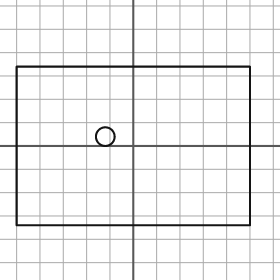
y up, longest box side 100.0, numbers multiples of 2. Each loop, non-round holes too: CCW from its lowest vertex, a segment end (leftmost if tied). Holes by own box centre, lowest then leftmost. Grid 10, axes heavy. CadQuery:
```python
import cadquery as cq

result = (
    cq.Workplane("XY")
    .moveTo(-50.0, -34.0)
    .lineTo(50.0, -34.0)
    .lineTo(50.0, 34.0)
    .lineTo(-50.0, 34.0)
    .close()
    .moveTo(-12.0, 4.0)
    .circle(4.0)
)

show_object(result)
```